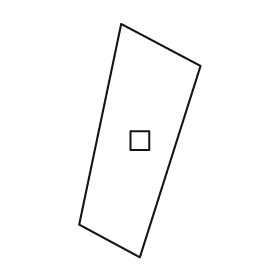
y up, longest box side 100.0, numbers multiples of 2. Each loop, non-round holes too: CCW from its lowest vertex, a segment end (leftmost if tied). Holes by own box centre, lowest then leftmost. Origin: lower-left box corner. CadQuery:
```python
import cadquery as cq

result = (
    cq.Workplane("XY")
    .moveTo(26.0, 0.0)
    .lineTo(52.0, 82.0)
    .lineTo(18.0, 100.0)
    .lineTo(0.0, 14.0)
    .close()
    .moveTo(22.0, 46.0)
    .lineTo(30.0, 46.0)
    .lineTo(30.0, 54.0)
    .lineTo(22.0, 54.0)
    .close()
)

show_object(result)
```